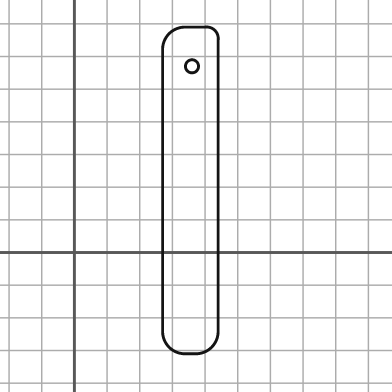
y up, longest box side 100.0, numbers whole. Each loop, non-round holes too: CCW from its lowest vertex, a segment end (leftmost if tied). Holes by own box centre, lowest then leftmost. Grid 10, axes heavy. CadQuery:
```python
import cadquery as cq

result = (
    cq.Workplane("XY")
    .moveTo(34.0, -31.0)
    .lineTo(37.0, -31.0)
    .threePointArc((42.0, -29.0), (44.0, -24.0))
    .lineTo(44.0, 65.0)
    .threePointArc((43.0, 68.0), (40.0, 69.0))
    .lineTo(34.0, 69.0)
    .threePointArc((29.0, 67.0), (27.0, 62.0))
    .lineTo(27.0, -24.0)
    .threePointArc((29.0, -29.0), (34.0, -31.0))
    .close()
    .moveTo(36.0, 57.0)
    .circle(2.0)
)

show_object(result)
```